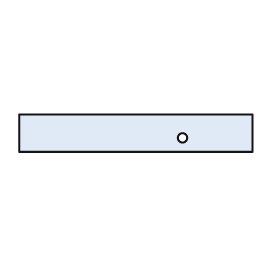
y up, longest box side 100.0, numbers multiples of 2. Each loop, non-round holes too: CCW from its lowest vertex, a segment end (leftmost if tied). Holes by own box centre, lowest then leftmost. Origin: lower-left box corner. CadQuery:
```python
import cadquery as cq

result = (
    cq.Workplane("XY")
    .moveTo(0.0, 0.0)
    .lineTo(100.0, 0.0)
    .lineTo(100.0, 16.0)
    .lineTo(0.0, 16.0)
    .close()
    .moveTo(70.0, 6.0)
    .circle(2.0)
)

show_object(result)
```